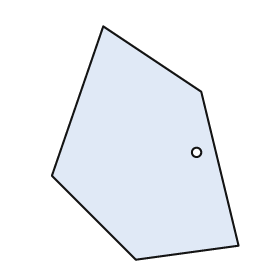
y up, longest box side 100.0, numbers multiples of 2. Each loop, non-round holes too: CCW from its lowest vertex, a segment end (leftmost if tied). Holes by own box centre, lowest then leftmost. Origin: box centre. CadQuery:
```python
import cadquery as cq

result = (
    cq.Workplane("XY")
    .moveTo(-4.0, -50.0)
    .lineTo(40.0, -44.0)
    .lineTo(24.0, 22.0)
    .lineTo(-18.0, 50.0)
    .lineTo(-40.0, -14.0)
    .close()
    .moveTo(22.0, -4.0)
    .circle(2.0)
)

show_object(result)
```